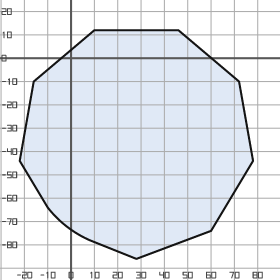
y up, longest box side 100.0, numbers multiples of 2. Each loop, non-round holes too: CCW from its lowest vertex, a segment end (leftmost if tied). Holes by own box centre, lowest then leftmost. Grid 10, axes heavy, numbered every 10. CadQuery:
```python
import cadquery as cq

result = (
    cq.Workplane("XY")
    .moveTo(28.0, -86.0)
    .lineTo(60.0, -74.0)
    .lineTo(78.0, -44.0)
    .lineTo(72.0, -10.0)
    .lineTo(46.0, 12.0)
    .lineTo(10.0, 12.0)
    .lineTo(-16.0, -10.0)
    .lineTo(-22.0, -44.0)
    .lineTo(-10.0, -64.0)
    .threePointArc((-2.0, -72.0), (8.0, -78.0))
    .close()
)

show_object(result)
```